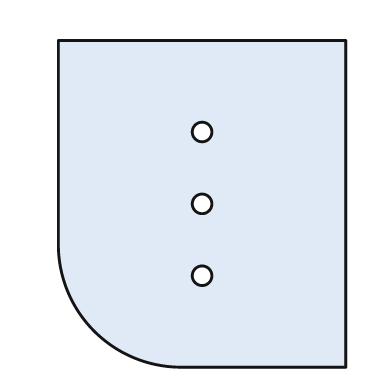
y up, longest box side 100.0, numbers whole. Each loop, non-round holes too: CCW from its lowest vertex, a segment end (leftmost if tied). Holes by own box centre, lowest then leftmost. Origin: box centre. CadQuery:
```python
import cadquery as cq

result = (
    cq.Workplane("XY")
    .moveTo(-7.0, -50.0)
    .lineTo(44.0, -50.0)
    .lineTo(44.0, 50.0)
    .lineTo(-44.0, 50.0)
    .lineTo(-44.0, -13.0)
    .threePointArc((-33.0, -39.0), (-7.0, -50.0))
    .close()
    .moveTo(0.0, -22.0)
    .circle(3.0)
    .moveTo(0.0, 0.0)
    .circle(3.0)
    .moveTo(0.0, 22.0)
    .circle(3.0)
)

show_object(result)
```